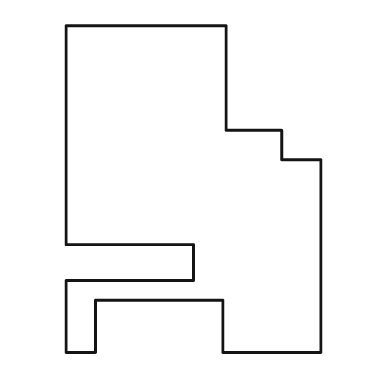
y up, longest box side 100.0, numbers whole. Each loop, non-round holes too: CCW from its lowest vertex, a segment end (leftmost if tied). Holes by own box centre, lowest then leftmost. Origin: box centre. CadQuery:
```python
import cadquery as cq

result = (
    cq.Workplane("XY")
    .moveTo(-39.0, -50.0)
    .lineTo(-30.0, -50.0)
    .lineTo(-30.0, -34.0)
    .lineTo(9.0, -34.0)
    .lineTo(9.0, -50.0)
    .lineTo(39.0, -50.0)
    .lineTo(39.0, 9.0)
    .lineTo(27.0, 9.0)
    .lineTo(27.0, 18.0)
    .lineTo(10.0, 18.0)
    .lineTo(10.0, 50.0)
    .lineTo(-39.0, 50.0)
    .lineTo(-39.0, -17.0)
    .lineTo(0.0, -17.0)
    .lineTo(0.0, -28.0)
    .lineTo(-39.0, -28.0)
    .close()
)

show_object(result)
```